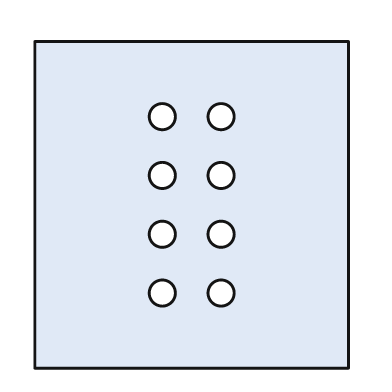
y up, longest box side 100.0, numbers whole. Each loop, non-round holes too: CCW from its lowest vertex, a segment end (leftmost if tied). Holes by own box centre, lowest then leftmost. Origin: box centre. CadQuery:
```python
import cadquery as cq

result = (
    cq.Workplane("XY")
    .moveTo(-48.0, -50.0)
    .lineTo(48.0, -50.0)
    .lineTo(48.0, 50.0)
    .lineTo(-48.0, 50.0)
    .close()
    .moveTo(-9.0, -27.0)
    .circle(4.0)
    .moveTo(9.0, -27.0)
    .circle(4.0)
    .moveTo(-9.0, -9.0)
    .circle(4.0)
    .moveTo(9.0, -9.0)
    .circle(4.0)
    .moveTo(-9.0, 9.0)
    .circle(4.0)
    .moveTo(9.0, 9.0)
    .circle(4.0)
    .moveTo(-9.0, 27.0)
    .circle(4.0)
    .moveTo(9.0, 27.0)
    .circle(4.0)
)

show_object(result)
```